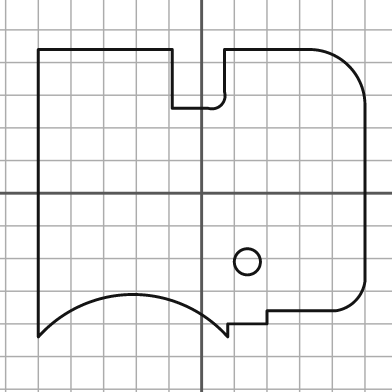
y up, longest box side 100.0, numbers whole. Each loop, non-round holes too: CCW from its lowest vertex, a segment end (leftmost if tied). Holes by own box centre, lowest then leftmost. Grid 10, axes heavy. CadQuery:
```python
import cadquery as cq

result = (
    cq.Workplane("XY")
    .moveTo(-50.0, -44.0)
    .threePointArc((-21.0, -31.0), (8.0, -44.0))
    .lineTo(8.0, -40.0)
    .lineTo(20.0, -40.0)
    .lineTo(20.0, -36.0)
    .lineTo(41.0, -36.0)
    .threePointArc((47.0, -33.0), (50.0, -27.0))
    .lineTo(50.0, 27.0)
    .threePointArc((45.0, 39.0), (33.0, 44.0))
    .lineTo(7.0, 44.0)
    .lineTo(7.0, 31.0)
    .threePointArc((6.0, 27.0), (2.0, 26.0))
    .lineTo(-9.0, 26.0)
    .lineTo(-9.0, 44.0)
    .lineTo(-50.0, 44.0)
    .close()
    .moveTo(14.0, -21.0)
    .circle(4.0)
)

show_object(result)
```